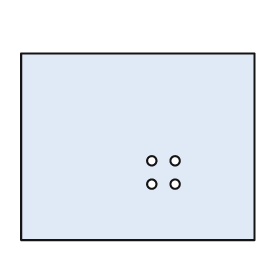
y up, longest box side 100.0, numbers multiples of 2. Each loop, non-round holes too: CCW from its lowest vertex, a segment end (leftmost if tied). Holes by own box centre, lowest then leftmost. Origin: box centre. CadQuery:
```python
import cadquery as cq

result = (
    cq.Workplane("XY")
    .moveTo(-50.0, -40.0)
    .lineTo(50.0, -40.0)
    .lineTo(50.0, 40.0)
    .lineTo(-50.0, 40.0)
    .close()
    .moveTo(6.0, -16.0)
    .circle(2.0)
    .moveTo(16.0, -16.0)
    .circle(2.0)
    .moveTo(6.0, -6.0)
    .circle(2.0)
    .moveTo(16.0, -6.0)
    .circle(2.0)
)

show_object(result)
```